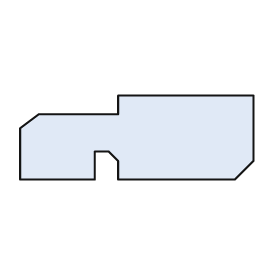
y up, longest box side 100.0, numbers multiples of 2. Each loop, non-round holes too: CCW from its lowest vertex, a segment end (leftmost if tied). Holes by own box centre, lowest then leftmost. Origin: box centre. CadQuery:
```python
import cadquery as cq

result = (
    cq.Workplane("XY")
    .moveTo(-50.0, -18.0)
    .lineTo(-18.0, -18.0)
    .lineTo(-18.0, -6.0)
    .lineTo(-12.0, -6.0)
    .lineTo(-8.0, -10.0)
    .lineTo(-8.0, -18.0)
    .lineTo(42.0, -18.0)
    .lineTo(50.0, -10.0)
    .lineTo(50.0, 18.0)
    .lineTo(-8.0, 18.0)
    .lineTo(-8.0, 10.0)
    .lineTo(-42.0, 10.0)
    .lineTo(-50.0, 4.0)
    .close()
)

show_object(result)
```